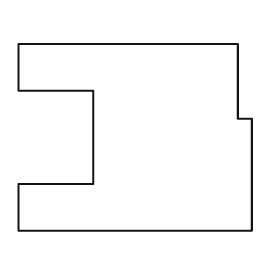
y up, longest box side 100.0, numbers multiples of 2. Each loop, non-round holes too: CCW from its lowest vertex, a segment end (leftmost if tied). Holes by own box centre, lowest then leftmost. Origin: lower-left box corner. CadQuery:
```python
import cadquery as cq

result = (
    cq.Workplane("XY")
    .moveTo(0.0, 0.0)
    .lineTo(100.0, 0.0)
    .lineTo(100.0, 48.0)
    .lineTo(94.0, 48.0)
    .lineTo(94.0, 80.0)
    .lineTo(0.0, 80.0)
    .lineTo(0.0, 60.0)
    .lineTo(32.0, 60.0)
    .lineTo(32.0, 20.0)
    .lineTo(0.0, 20.0)
    .close()
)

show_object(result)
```